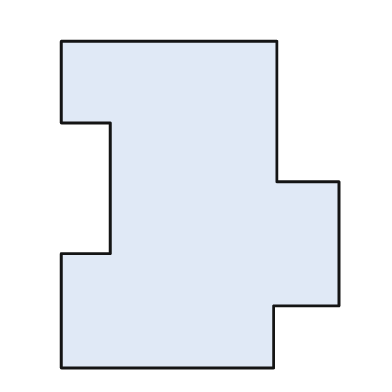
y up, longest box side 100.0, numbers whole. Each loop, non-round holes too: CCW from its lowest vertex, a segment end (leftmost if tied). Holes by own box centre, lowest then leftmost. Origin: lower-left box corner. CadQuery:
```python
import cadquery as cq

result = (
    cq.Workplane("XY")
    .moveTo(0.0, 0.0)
    .lineTo(65.0, 0.0)
    .lineTo(65.0, 19.0)
    .lineTo(85.0, 19.0)
    .lineTo(85.0, 57.0)
    .lineTo(66.0, 57.0)
    .lineTo(66.0, 100.0)
    .lineTo(0.0, 100.0)
    .lineTo(0.0, 75.0)
    .lineTo(15.0, 75.0)
    .lineTo(15.0, 35.0)
    .lineTo(0.0, 35.0)
    .close()
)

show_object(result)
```